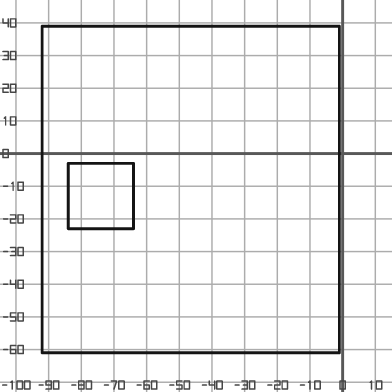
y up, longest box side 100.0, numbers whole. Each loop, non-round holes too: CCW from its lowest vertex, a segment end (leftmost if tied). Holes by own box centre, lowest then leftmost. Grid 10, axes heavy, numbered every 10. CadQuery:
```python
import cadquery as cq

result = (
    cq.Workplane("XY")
    .moveTo(-92.0, -61.0)
    .lineTo(-1.0, -61.0)
    .lineTo(-1.0, 39.0)
    .lineTo(-92.0, 39.0)
    .close()
    .moveTo(-84.0, -23.0)
    .lineTo(-64.0, -23.0)
    .lineTo(-64.0, -3.0)
    .lineTo(-84.0, -3.0)
    .close()
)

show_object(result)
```